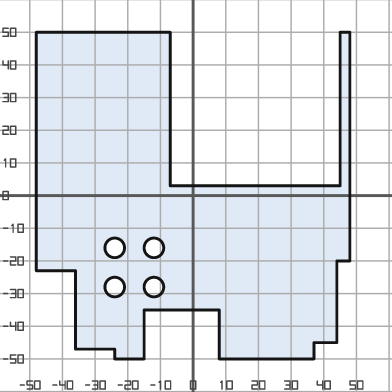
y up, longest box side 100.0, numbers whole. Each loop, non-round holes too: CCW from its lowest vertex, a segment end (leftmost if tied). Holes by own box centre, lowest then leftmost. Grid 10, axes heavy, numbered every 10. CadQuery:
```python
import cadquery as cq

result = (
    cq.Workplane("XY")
    .moveTo(-24.0, -50.0)
    .lineTo(-15.0, -50.0)
    .lineTo(-15.0, -35.0)
    .lineTo(8.0, -35.0)
    .lineTo(8.0, -50.0)
    .lineTo(37.0, -50.0)
    .lineTo(37.0, -45.0)
    .lineTo(44.0, -45.0)
    .lineTo(44.0, -20.0)
    .lineTo(48.0, -20.0)
    .lineTo(48.0, 50.0)
    .lineTo(45.0, 50.0)
    .lineTo(45.0, 3.0)
    .lineTo(-7.0, 3.0)
    .lineTo(-7.0, 50.0)
    .lineTo(-48.0, 50.0)
    .lineTo(-48.0, -23.0)
    .lineTo(-36.0, -23.0)
    .lineTo(-36.0, -47.0)
    .lineTo(-24.0, -47.0)
    .close()
    .moveTo(-24.0, -28.0)
    .circle(3.0)
    .moveTo(-12.0, -28.0)
    .circle(3.0)
    .moveTo(-24.0, -16.0)
    .circle(3.0)
    .moveTo(-12.0, -16.0)
    .circle(3.0)
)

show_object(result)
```